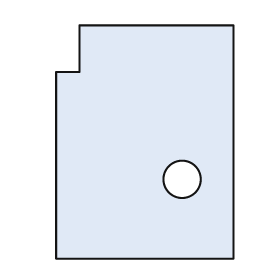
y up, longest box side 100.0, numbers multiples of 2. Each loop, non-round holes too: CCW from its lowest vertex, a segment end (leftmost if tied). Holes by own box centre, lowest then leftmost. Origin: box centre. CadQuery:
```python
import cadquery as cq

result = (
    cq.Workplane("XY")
    .moveTo(-38.0, -50.0)
    .lineTo(38.0, -50.0)
    .lineTo(38.0, 50.0)
    .lineTo(-28.0, 50.0)
    .lineTo(-28.0, 30.0)
    .lineTo(-38.0, 30.0)
    .close()
    .moveTo(16.0, -16.0)
    .circle(8.0)
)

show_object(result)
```